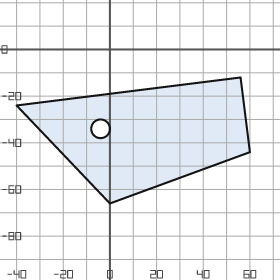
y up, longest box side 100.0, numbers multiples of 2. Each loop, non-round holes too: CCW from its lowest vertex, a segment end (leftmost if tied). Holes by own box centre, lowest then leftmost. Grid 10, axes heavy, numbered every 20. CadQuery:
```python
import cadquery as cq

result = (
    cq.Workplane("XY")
    .moveTo(0.0, -66.0)
    .lineTo(60.0, -44.0)
    .lineTo(56.0, -12.0)
    .lineTo(-40.0, -24.0)
    .close()
    .moveTo(-4.0, -34.0)
    .circle(4.0)
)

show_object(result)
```